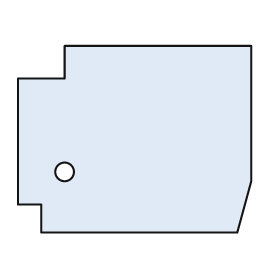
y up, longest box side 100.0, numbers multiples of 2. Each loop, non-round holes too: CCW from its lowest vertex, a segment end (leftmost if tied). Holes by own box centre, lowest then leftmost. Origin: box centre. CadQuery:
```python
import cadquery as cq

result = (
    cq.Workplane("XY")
    .moveTo(-40.0, -40.0)
    .lineTo(44.0, -40.0)
    .lineTo(50.0, -18.0)
    .lineTo(50.0, 40.0)
    .lineTo(-30.0, 40.0)
    .lineTo(-30.0, 26.0)
    .lineTo(-50.0, 26.0)
    .lineTo(-50.0, -28.0)
    .lineTo(-40.0, -28.0)
    .close()
    .moveTo(-30.0, -14.0)
    .circle(4.0)
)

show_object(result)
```